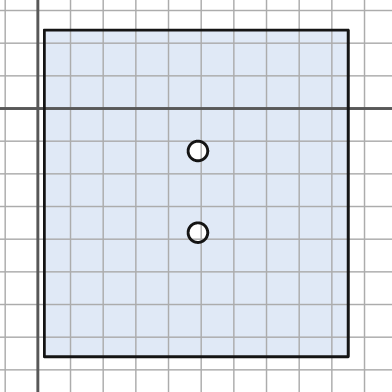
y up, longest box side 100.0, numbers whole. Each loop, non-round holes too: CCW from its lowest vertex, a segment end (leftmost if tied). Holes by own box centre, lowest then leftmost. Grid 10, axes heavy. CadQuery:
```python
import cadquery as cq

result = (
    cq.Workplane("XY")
    .moveTo(2.0, -76.0)
    .lineTo(95.0, -76.0)
    .lineTo(95.0, 24.0)
    .lineTo(2.0, 24.0)
    .close()
    .moveTo(49.0, -38.0)
    .circle(3.0)
    .moveTo(49.0, -13.0)
    .circle(3.0)
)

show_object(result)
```